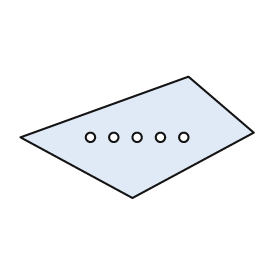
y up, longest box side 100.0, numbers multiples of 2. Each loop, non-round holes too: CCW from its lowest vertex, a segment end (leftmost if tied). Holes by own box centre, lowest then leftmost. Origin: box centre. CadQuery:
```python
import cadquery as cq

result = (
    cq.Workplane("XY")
    .moveTo(-2.0, -26.0)
    .lineTo(50.0, 2.0)
    .lineTo(22.0, 26.0)
    .lineTo(-50.0, 0.0)
    .close()
    .moveTo(-20.0, 0.0)
    .circle(2.0)
    .moveTo(-10.0, 0.0)
    .circle(2.0)
    .moveTo(0.0, 0.0)
    .circle(2.0)
    .moveTo(10.0, 0.0)
    .circle(2.0)
    .moveTo(20.0, 0.0)
    .circle(2.0)
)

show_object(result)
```